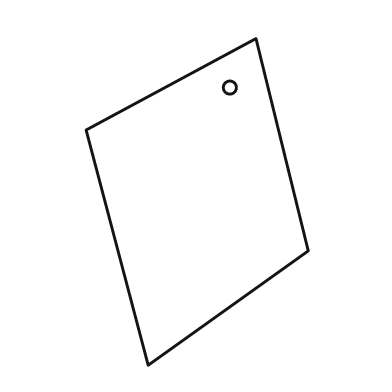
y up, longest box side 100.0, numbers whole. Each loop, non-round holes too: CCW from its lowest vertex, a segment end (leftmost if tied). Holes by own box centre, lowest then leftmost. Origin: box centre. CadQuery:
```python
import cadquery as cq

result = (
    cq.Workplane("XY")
    .moveTo(-15.0, -50.0)
    .lineTo(34.0, -15.0)
    .lineTo(18.0, 50.0)
    .lineTo(-34.0, 22.0)
    .close()
    .moveTo(10.0, 35.0)
    .circle(2.0)
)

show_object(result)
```